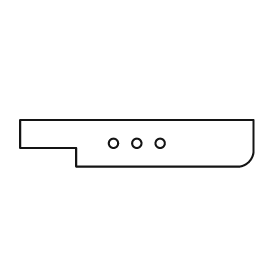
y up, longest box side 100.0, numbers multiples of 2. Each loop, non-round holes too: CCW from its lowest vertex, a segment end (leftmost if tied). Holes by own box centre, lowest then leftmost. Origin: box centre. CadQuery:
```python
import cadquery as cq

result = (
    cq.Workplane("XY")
    .moveTo(-26.0, -10.0)
    .lineTo(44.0, -10.0)
    .threePointArc((48.0, -8.0), (50.0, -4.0))
    .lineTo(50.0, 10.0)
    .lineTo(-50.0, 10.0)
    .lineTo(-50.0, -2.0)
    .lineTo(-26.0, -2.0)
    .close()
    .moveTo(-10.0, 0.0)
    .circle(2.0)
    .moveTo(0.0, 0.0)
    .circle(2.0)
    .moveTo(10.0, 0.0)
    .circle(2.0)
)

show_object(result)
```